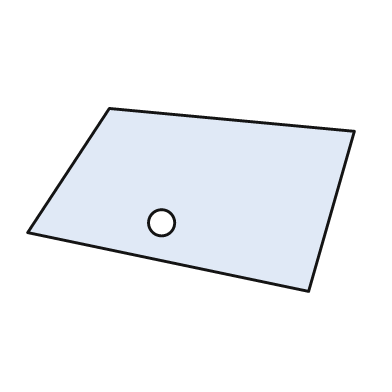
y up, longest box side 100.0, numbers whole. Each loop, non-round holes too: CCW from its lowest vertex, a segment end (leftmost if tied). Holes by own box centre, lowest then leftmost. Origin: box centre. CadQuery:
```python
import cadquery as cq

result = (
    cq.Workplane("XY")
    .moveTo(36.0, -28.0)
    .lineTo(50.0, 21.0)
    .lineTo(-25.0, 28.0)
    .lineTo(-50.0, -10.0)
    .close()
    .moveTo(-9.0, -7.0)
    .circle(4.0)
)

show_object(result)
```